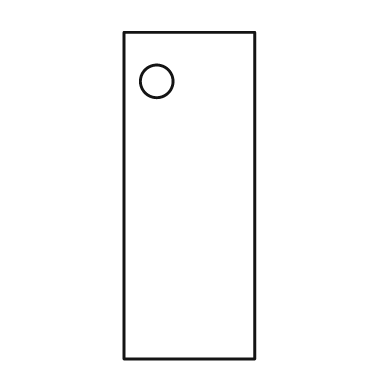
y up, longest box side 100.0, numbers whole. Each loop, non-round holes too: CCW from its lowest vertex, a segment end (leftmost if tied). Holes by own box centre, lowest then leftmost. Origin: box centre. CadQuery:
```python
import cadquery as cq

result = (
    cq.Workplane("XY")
    .moveTo(-20.0, -50.0)
    .lineTo(20.0, -50.0)
    .lineTo(20.0, 50.0)
    .lineTo(-20.0, 50.0)
    .close()
    .moveTo(-10.0, 35.0)
    .circle(5.0)
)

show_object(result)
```